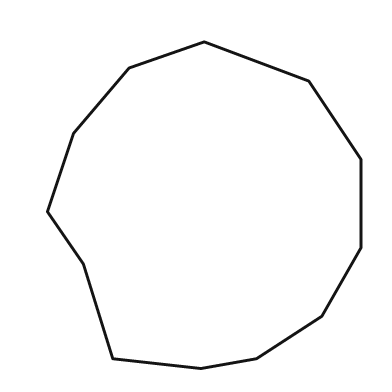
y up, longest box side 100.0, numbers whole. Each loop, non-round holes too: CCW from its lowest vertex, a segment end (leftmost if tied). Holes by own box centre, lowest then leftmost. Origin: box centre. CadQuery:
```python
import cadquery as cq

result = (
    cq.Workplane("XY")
    .moveTo(-1.0, -50.0)
    .lineTo(16.0, -47.0)
    .lineTo(36.0, -34.0)
    .lineTo(48.0, -13.0)
    .lineTo(48.0, 14.0)
    .lineTo(32.0, 38.0)
    .lineTo(0.0, 50.0)
    .lineTo(-23.0, 42.0)
    .lineTo(-40.0, 22.0)
    .lineTo(-48.0, -2.0)
    .lineTo(-37.0, -18.0)
    .lineTo(-28.0, -47.0)
    .close()
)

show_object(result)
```